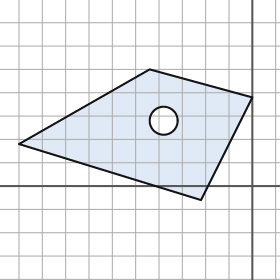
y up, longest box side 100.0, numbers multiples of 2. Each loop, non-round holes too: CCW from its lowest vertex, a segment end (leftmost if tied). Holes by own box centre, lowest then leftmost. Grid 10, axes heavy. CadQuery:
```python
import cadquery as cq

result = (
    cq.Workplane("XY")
    .moveTo(-22.0, -6.0)
    .lineTo(0.0, 38.0)
    .lineTo(-44.0, 50.0)
    .lineTo(-100.0, 18.0)
    .close()
    .moveTo(-38.0, 28.0)
    .circle(6.0)
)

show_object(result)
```